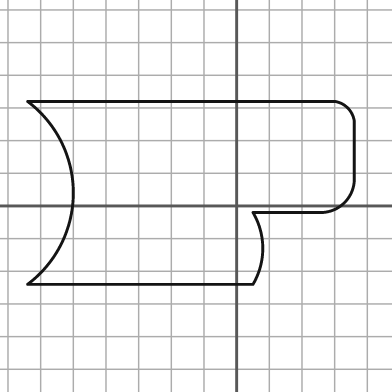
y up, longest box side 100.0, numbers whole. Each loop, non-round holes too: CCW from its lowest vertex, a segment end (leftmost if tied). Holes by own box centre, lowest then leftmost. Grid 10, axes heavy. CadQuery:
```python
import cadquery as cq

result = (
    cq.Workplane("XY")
    .moveTo(-64.0, -24.0)
    .lineTo(5.0, -24.0)
    .threePointArc((8.0, -13.0), (5.0, -2.0))
    .lineTo(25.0, -2.0)
    .threePointArc((33.0, 1.0), (36.0, 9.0))
    .lineTo(36.0, 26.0)
    .threePointArc((34.0, 30.0), (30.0, 32.0))
    .lineTo(-64.0, 32.0)
    .threePointArc((-50.0, 4.0), (-64.0, -24.0))
    .close()
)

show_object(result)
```